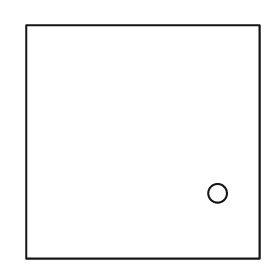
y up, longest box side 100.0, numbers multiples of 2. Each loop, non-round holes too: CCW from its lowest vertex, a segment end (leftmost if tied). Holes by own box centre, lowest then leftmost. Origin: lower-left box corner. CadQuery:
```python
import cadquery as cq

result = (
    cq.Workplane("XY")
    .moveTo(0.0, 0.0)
    .lineTo(100.0, 0.0)
    .lineTo(100.0, 100.0)
    .lineTo(0.0, 100.0)
    .close()
    .moveTo(82.0, 28.0)
    .circle(4.0)
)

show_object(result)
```